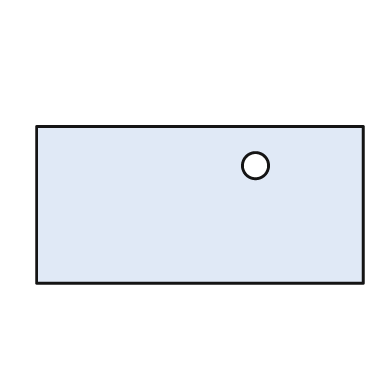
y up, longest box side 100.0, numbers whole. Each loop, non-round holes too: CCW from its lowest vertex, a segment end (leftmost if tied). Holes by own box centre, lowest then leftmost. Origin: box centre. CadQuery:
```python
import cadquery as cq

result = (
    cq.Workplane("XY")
    .moveTo(-50.0, -24.0)
    .lineTo(50.0, -24.0)
    .lineTo(50.0, 24.0)
    .lineTo(-50.0, 24.0)
    .close()
    .moveTo(17.0, 12.0)
    .circle(4.0)
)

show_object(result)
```